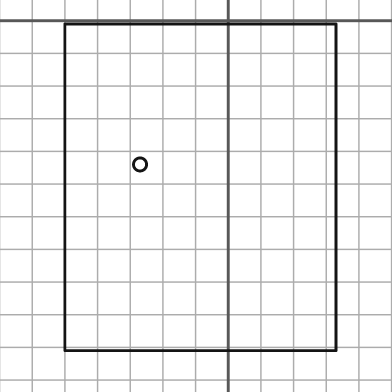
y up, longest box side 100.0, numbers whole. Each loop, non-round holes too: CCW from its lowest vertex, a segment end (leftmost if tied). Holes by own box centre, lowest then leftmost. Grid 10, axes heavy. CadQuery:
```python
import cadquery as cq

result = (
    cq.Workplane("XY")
    .moveTo(-50.0, -101.0)
    .lineTo(33.0, -101.0)
    .lineTo(33.0, -1.0)
    .lineTo(-50.0, -1.0)
    .close()
    .moveTo(-27.0, -44.0)
    .circle(2.0)
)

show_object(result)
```